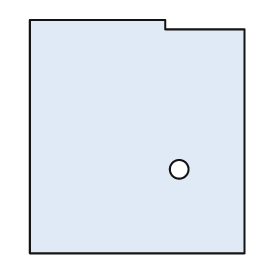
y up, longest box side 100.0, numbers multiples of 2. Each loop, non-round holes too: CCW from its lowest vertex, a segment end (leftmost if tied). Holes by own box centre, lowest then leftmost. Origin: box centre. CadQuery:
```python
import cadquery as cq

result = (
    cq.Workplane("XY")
    .moveTo(-46.0, -50.0)
    .lineTo(46.0, -50.0)
    .lineTo(46.0, 46.0)
    .lineTo(12.0, 46.0)
    .lineTo(12.0, 50.0)
    .lineTo(-46.0, 50.0)
    .close()
    .moveTo(18.0, -14.0)
    .circle(4.0)
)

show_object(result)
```